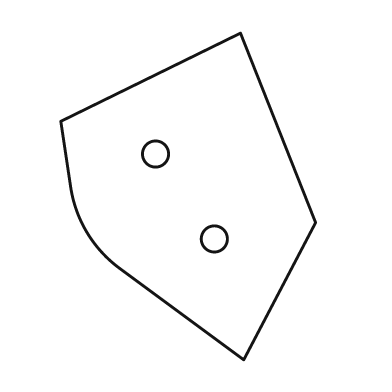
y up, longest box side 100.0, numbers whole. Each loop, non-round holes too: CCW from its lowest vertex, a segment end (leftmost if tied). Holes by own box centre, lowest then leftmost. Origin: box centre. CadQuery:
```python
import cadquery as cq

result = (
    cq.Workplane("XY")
    .moveTo(17.0, -50.0)
    .lineTo(39.0, -8.0)
    .lineTo(16.0, 50.0)
    .lineTo(-39.0, 23.0)
    .lineTo(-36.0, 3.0)
    .threePointArc((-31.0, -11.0), (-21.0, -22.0))
    .close()
    .moveTo(8.0, -13.0)
    .circle(4.0)
    .moveTo(-10.0, 13.0)
    .circle(4.0)
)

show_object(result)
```